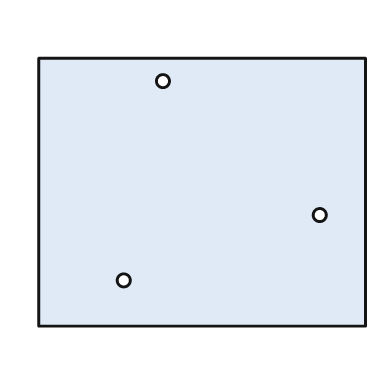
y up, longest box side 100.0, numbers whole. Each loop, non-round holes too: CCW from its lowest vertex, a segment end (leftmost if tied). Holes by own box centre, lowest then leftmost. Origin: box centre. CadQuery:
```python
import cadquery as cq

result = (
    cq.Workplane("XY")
    .moveTo(-50.0, -41.0)
    .lineTo(50.0, -41.0)
    .lineTo(50.0, 41.0)
    .lineTo(-50.0, 41.0)
    .close()
    .moveTo(-24.0, -27.0)
    .circle(2.0)
    .moveTo(36.0, -7.0)
    .circle(2.0)
    .moveTo(-12.0, 34.0)
    .circle(2.0)
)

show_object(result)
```